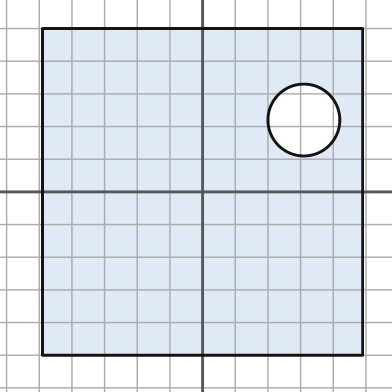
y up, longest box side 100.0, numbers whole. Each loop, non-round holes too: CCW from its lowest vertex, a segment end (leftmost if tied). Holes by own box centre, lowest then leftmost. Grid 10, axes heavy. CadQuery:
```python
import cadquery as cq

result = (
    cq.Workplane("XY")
    .moveTo(-49.0, -50.0)
    .lineTo(49.0, -50.0)
    .lineTo(49.0, 50.0)
    .lineTo(-49.0, 50.0)
    .close()
    .moveTo(31.0, 22.0)
    .circle(11.0)
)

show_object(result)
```